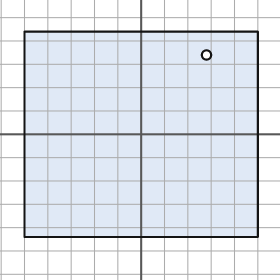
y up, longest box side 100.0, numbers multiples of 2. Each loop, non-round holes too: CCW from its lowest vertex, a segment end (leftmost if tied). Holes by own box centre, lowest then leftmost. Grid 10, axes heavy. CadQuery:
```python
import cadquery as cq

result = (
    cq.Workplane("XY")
    .moveTo(-50.0, -44.0)
    .lineTo(50.0, -44.0)
    .lineTo(50.0, 44.0)
    .lineTo(-50.0, 44.0)
    .close()
    .moveTo(28.0, 34.0)
    .circle(2.0)
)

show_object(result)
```